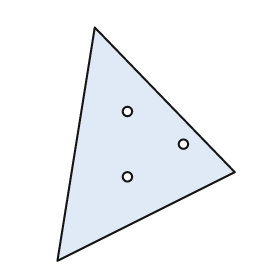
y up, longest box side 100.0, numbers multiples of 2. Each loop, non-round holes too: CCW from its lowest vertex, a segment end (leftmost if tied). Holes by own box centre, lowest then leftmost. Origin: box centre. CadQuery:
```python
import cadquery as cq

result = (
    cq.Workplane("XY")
    .moveTo(-38.0, -50.0)
    .lineTo(38.0, -12.0)
    .lineTo(-22.0, 50.0)
    .close()
    .moveTo(-8.0, -14.0)
    .circle(2.0)
    .moveTo(16.0, 0.0)
    .circle(2.0)
    .moveTo(-8.0, 14.0)
    .circle(2.0)
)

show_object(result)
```